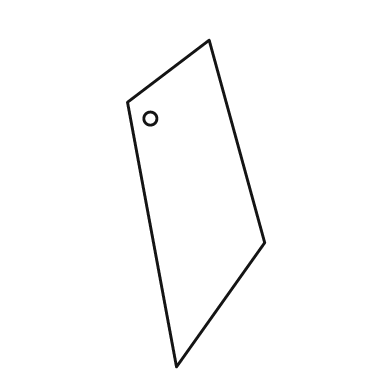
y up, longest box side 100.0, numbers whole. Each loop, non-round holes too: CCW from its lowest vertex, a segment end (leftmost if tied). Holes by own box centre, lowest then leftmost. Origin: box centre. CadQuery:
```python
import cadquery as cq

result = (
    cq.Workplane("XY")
    .moveTo(-6.0, -50.0)
    .lineTo(21.0, -12.0)
    .lineTo(4.0, 50.0)
    .lineTo(-21.0, 31.0)
    .close()
    .moveTo(-14.0, 26.0)
    .circle(2.0)
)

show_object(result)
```